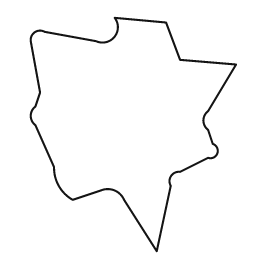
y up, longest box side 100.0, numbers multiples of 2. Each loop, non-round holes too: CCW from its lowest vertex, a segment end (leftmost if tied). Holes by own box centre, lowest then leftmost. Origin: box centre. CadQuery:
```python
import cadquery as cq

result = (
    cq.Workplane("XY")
    .moveTo(10.0, -50.0)
    .lineTo(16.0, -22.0)
    .threePointArc((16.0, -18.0), (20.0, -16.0))
    .lineTo(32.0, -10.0)
    .threePointArc((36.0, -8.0), (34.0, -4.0))
    .lineTo(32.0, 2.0)
    .threePointArc((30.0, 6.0), (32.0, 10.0))
    .lineTo(44.0, 30.0)
    .lineTo(20.0, 32.0)
    .lineTo(14.0, 48.0)
    .lineTo(-8.0, 50.0)
    .threePointArc((-8.0, 42.0), (-16.0, 40.0))
    .lineTo(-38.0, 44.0)
    .threePointArc((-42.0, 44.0), (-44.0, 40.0))
    .lineTo(-40.0, 18.0)
    .lineTo(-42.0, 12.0)
    .threePointArc((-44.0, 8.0), (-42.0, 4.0))
    .lineTo(-34.0, -14.0)
    .threePointArc((-32.0, -22.0), (-26.0, -28.0))
    .lineTo(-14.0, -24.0)
    .threePointArc((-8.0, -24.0), (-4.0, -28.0))
    .close()
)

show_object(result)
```